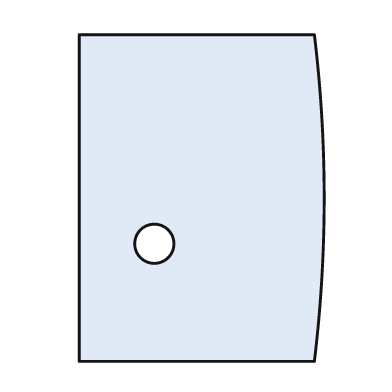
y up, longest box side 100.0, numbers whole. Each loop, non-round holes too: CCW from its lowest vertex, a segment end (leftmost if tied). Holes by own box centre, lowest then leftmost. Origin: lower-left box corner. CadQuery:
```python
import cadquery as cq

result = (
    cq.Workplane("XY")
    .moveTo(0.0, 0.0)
    .lineTo(72.0, 0.0)
    .threePointArc((75.0, 50.0), (72.0, 100.0))
    .lineTo(0.0, 100.0)
    .close()
    .moveTo(23.0, 36.0)
    .circle(6.0)
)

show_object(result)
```